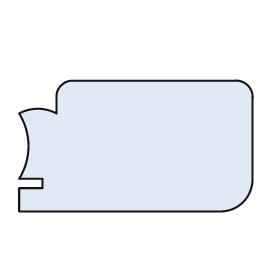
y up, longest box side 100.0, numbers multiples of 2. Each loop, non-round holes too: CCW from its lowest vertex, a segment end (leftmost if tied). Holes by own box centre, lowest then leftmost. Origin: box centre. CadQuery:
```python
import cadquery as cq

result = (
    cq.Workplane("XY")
    .moveTo(-50.0, -28.0)
    .lineTo(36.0, -28.0)
    .threePointArc((46.0, -24.0), (50.0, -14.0))
    .lineTo(50.0, 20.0)
    .threePointArc((48.0, 26.0), (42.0, 28.0))
    .lineTo(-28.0, 28.0)
    .threePointArc((-32.0, 26.0), (-34.0, 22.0))
    .lineTo(-34.0, 14.0)
    .threePointArc((-42.0, 16.0), (-50.0, 14.0))
    .threePointArc((-46.0, 0.0), (-50.0, -14.0))
    .lineTo(-40.0, -14.0)
    .lineTo(-40.0, -18.0)
    .lineTo(-50.0, -18.0)
    .close()
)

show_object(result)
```